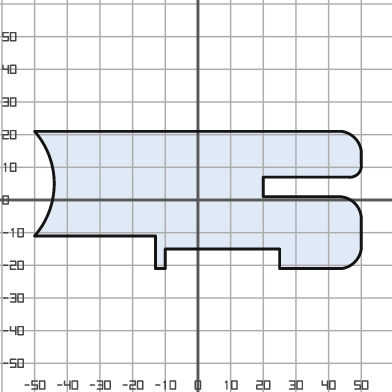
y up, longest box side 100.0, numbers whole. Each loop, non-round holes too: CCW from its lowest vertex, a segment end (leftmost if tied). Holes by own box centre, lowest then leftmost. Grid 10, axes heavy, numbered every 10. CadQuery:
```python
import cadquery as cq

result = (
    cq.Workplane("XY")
    .moveTo(-13.0, -21.0)
    .lineTo(-10.0, -21.0)
    .lineTo(-10.0, -15.0)
    .lineTo(25.0, -15.0)
    .lineTo(25.0, -21.0)
    .lineTo(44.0, -21.0)
    .threePointArc((48.0, -19.0), (50.0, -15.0))
    .lineTo(50.0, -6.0)
    .threePointArc((48.0, -1.0), (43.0, 1.0))
    .lineTo(20.0, 1.0)
    .lineTo(20.0, 7.0)
    .lineTo(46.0, 7.0)
    .threePointArc((49.0, 8.0), (50.0, 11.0))
    .lineTo(50.0, 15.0)
    .threePointArc((48.0, 19.0), (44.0, 21.0))
    .lineTo(-50.0, 21.0)
    .threePointArc((-44.0, 5.0), (-50.0, -11.0))
    .lineTo(-13.0, -11.0)
    .close()
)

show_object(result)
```